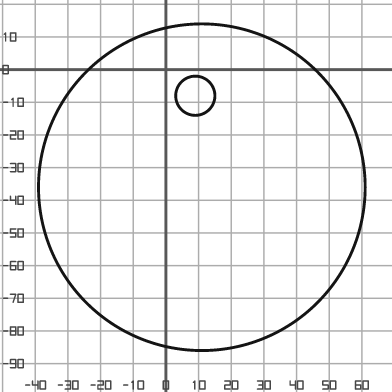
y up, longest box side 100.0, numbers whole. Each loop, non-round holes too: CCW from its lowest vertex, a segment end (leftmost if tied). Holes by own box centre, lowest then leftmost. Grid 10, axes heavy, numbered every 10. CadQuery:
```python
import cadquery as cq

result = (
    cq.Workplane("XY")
    .moveTo(11.0, -36.0)
    .circle(50.0)
    .moveTo(9.0, -8.0)
    .circle(6.0)
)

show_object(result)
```